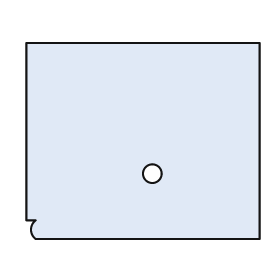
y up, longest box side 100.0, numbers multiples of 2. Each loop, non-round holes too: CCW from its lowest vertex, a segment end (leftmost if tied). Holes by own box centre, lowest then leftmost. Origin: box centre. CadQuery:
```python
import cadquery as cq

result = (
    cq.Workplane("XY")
    .moveTo(-46.0, -42.0)
    .lineTo(50.0, -42.0)
    .lineTo(50.0, 42.0)
    .lineTo(-50.0, 42.0)
    .lineTo(-50.0, -34.0)
    .lineTo(-46.0, -34.0)
    .threePointArc((-48.0, -38.0), (-46.0, -42.0))
    .close()
    .moveTo(4.0, -14.0)
    .circle(4.0)
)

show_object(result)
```